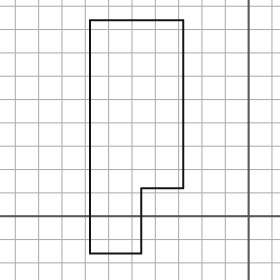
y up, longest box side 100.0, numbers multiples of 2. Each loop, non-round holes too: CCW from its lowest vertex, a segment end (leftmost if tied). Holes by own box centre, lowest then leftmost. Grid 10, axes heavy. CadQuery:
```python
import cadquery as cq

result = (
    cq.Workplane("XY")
    .moveTo(-68.0, -16.0)
    .lineTo(-46.0, -16.0)
    .lineTo(-46.0, 12.0)
    .lineTo(-28.0, 12.0)
    .lineTo(-28.0, 84.0)
    .lineTo(-68.0, 84.0)
    .close()
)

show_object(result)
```